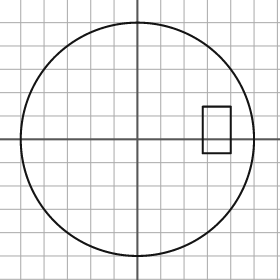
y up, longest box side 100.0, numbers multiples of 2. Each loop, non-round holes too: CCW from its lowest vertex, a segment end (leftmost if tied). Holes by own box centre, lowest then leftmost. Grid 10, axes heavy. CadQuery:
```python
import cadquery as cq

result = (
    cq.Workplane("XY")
    .moveTo(0.0, 0.0)
    .circle(50.0)
    .moveTo(28.0, -6.0)
    .lineTo(40.0, -6.0)
    .lineTo(40.0, 14.0)
    .lineTo(28.0, 14.0)
    .close()
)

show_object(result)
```